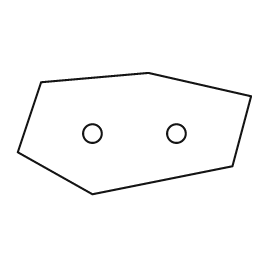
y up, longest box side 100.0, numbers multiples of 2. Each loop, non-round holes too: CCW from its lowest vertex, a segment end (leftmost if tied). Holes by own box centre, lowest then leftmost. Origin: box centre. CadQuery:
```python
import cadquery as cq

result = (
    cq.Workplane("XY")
    .moveTo(-18.0, -26.0)
    .lineTo(42.0, -14.0)
    .lineTo(50.0, 16.0)
    .lineTo(6.0, 26.0)
    .lineTo(-40.0, 22.0)
    .lineTo(-50.0, -8.0)
    .close()
    .moveTo(-18.0, 0.0)
    .circle(4.0)
    .moveTo(18.0, 0.0)
    .circle(4.0)
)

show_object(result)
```